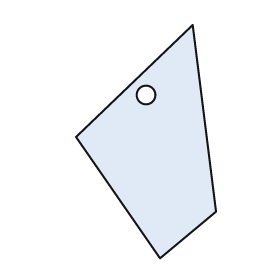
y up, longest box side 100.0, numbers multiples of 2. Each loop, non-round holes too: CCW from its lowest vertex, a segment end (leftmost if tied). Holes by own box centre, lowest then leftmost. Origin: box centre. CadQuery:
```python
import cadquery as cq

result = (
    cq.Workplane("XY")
    .moveTo(6.0, -50.0)
    .lineTo(30.0, -30.0)
    .lineTo(20.0, 50.0)
    .lineTo(-30.0, 2.0)
    .close()
    .moveTo(0.0, 20.0)
    .circle(4.0)
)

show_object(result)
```